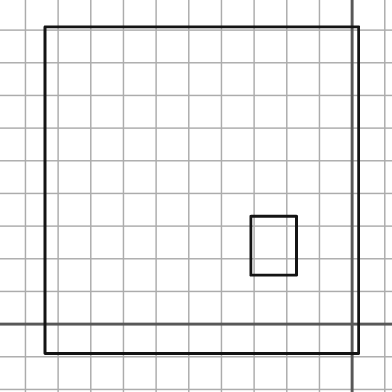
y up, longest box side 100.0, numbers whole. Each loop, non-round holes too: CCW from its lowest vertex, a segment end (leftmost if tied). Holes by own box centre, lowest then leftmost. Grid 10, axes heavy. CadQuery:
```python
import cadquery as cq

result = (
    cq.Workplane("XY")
    .moveTo(-94.0, -9.0)
    .lineTo(2.0, -9.0)
    .lineTo(2.0, 91.0)
    .lineTo(-94.0, 91.0)
    .close()
    .moveTo(-31.0, 15.0)
    .lineTo(-17.0, 15.0)
    .lineTo(-17.0, 33.0)
    .lineTo(-31.0, 33.0)
    .close()
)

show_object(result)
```